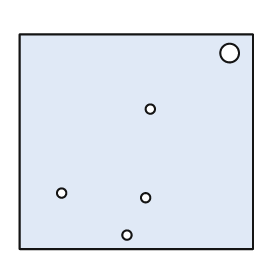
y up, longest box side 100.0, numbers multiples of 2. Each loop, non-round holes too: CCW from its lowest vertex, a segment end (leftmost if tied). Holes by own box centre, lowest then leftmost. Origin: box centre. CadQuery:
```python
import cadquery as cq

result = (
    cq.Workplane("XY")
    .moveTo(-50.0, -46.0)
    .lineTo(50.0, -46.0)
    .lineTo(50.0, 46.0)
    .lineTo(-50.0, 46.0)
    .close()
    .moveTo(-4.0, -40.0)
    .circle(2.0)
    .moveTo(4.0, -24.0)
    .circle(2.0)
    .moveTo(-32.0, -22.0)
    .circle(2.0)
    .moveTo(6.0, 14.0)
    .circle(2.0)
    .moveTo(40.0, 38.0)
    .circle(4.0)
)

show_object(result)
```